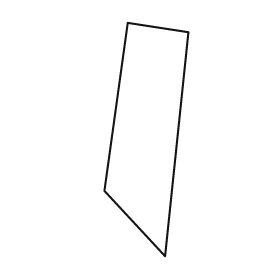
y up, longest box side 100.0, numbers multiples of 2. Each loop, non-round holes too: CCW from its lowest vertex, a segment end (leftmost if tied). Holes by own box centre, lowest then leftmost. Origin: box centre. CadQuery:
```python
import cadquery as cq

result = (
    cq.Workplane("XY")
    .moveTo(8.0, -50.0)
    .lineTo(18.0, 46.0)
    .lineTo(-8.0, 50.0)
    .lineTo(-18.0, -22.0)
    .close()
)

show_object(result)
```